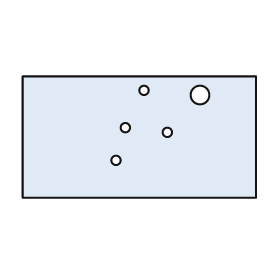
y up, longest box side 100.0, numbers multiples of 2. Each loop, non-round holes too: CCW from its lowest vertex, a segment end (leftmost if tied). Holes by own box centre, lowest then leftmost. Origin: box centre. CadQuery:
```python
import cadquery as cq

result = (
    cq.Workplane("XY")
    .moveTo(-50.0, -26.0)
    .lineTo(50.0, -26.0)
    .lineTo(50.0, 26.0)
    .lineTo(-50.0, 26.0)
    .close()
    .moveTo(-10.0, -10.0)
    .circle(2.0)
    .moveTo(12.0, 2.0)
    .circle(2.0)
    .moveTo(-6.0, 4.0)
    .circle(2.0)
    .moveTo(26.0, 18.0)
    .circle(4.0)
    .moveTo(2.0, 20.0)
    .circle(2.0)
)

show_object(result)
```